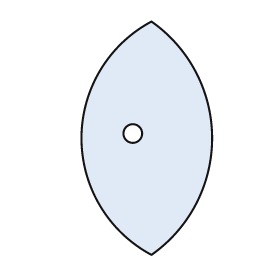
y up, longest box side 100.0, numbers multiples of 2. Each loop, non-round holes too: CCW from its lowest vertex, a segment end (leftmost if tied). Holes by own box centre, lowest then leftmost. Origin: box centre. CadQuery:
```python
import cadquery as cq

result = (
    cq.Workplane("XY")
    .moveTo(2.0, -50.0)
    .threePointArc((28.0, 0.0), (2.0, 50.0))
    .threePointArc((-28.0, 0.0), (2.0, -50.0))
    .close()
    .moveTo(-6.0, 2.0)
    .circle(4.0)
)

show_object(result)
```